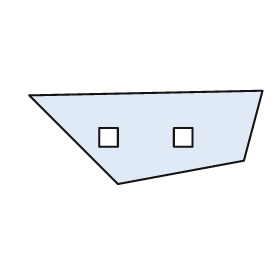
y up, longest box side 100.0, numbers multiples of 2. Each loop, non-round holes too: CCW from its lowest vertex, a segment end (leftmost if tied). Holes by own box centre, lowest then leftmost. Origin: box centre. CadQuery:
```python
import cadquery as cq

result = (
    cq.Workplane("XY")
    .moveTo(-12.0, -20.0)
    .lineTo(42.0, -10.0)
    .lineTo(50.0, 20.0)
    .lineTo(-50.0, 18.0)
    .close()
    .moveTo(-20.0, -4.0)
    .lineTo(-12.0, -4.0)
    .lineTo(-12.0, 4.0)
    .lineTo(-20.0, 4.0)
    .close()
    .moveTo(12.0, -4.0)
    .lineTo(20.0, -4.0)
    .lineTo(20.0, 4.0)
    .lineTo(12.0, 4.0)
    .close()
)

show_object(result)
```